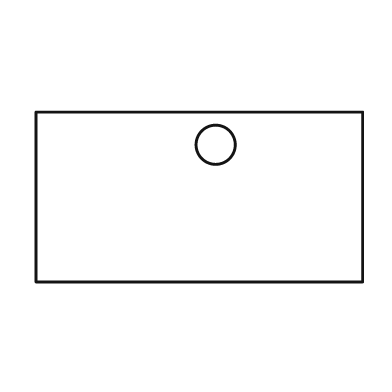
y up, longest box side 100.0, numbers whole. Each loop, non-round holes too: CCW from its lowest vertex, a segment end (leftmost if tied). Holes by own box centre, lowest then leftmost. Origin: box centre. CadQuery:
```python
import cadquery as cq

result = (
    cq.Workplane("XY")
    .moveTo(-50.0, -26.0)
    .lineTo(50.0, -26.0)
    .lineTo(50.0, 26.0)
    .lineTo(-50.0, 26.0)
    .close()
    .moveTo(5.0, 16.0)
    .circle(6.0)
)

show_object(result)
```